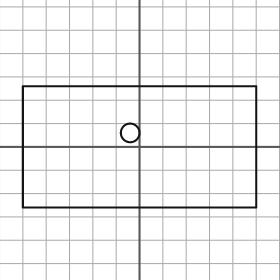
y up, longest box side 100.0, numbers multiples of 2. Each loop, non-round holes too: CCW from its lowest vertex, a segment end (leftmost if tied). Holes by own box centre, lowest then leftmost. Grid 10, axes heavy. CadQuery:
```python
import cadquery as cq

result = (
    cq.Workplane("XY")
    .moveTo(-50.0, -26.0)
    .lineTo(50.0, -26.0)
    .lineTo(50.0, 26.0)
    .lineTo(-50.0, 26.0)
    .close()
    .moveTo(-4.0, 6.0)
    .circle(4.0)
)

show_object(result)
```